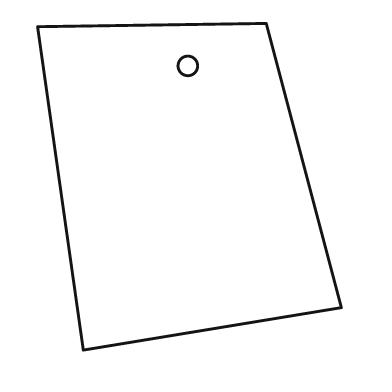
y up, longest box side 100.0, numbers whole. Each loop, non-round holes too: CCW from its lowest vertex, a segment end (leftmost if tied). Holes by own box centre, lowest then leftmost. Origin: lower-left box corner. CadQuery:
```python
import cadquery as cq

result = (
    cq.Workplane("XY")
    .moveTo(14.0, 0.0)
    .lineTo(93.0, 13.0)
    .lineTo(70.0, 100.0)
    .lineTo(0.0, 99.0)
    .close()
    .moveTo(46.0, 87.0)
    .circle(3.0)
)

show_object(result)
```